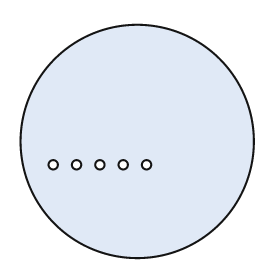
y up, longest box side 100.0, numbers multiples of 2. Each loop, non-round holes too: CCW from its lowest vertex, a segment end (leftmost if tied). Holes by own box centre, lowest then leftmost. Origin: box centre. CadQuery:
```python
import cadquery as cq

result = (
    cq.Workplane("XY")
    .moveTo(0.0, 0.0)
    .circle(50.0)
    .moveTo(-36.0, -10.0)
    .circle(2.0)
    .moveTo(-26.0, -10.0)
    .circle(2.0)
    .moveTo(-16.0, -10.0)
    .circle(2.0)
    .moveTo(-6.0, -10.0)
    .circle(2.0)
    .moveTo(4.0, -10.0)
    .circle(2.0)
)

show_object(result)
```